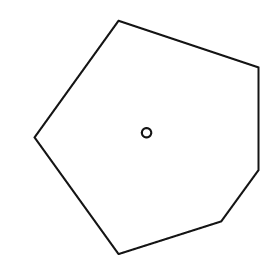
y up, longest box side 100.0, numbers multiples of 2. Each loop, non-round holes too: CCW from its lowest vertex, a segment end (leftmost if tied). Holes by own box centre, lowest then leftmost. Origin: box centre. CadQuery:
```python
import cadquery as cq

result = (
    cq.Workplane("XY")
    .moveTo(-12.0, -50.0)
    .lineTo(32.0, -36.0)
    .lineTo(48.0, -14.0)
    .lineTo(48.0, 30.0)
    .lineTo(-12.0, 50.0)
    .lineTo(-48.0, 0.0)
    .close()
    .moveTo(0.0, 2.0)
    .circle(2.0)
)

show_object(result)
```